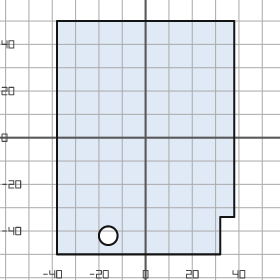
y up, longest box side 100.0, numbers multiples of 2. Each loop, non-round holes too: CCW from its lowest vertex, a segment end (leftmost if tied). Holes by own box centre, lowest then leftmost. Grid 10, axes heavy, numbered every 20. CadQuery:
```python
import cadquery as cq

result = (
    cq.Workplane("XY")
    .moveTo(-38.0, -50.0)
    .lineTo(32.0, -50.0)
    .lineTo(32.0, -34.0)
    .lineTo(38.0, -34.0)
    .lineTo(38.0, 50.0)
    .lineTo(-38.0, 50.0)
    .close()
    .moveTo(-16.0, -42.0)
    .circle(4.0)
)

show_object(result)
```